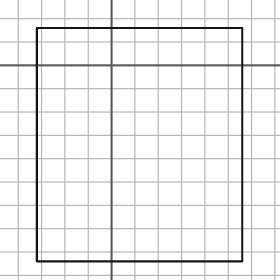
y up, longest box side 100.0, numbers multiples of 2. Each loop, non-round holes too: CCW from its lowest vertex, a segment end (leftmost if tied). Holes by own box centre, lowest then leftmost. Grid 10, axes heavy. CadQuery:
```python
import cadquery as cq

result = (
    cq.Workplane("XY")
    .moveTo(-32.0, -84.0)
    .lineTo(56.0, -84.0)
    .lineTo(56.0, 16.0)
    .lineTo(-32.0, 16.0)
    .close()
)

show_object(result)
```